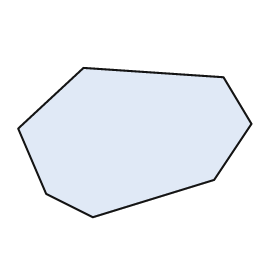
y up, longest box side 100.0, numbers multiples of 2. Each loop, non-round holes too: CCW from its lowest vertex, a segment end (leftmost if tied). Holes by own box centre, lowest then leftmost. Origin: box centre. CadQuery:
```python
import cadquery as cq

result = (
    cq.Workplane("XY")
    .moveTo(-18.0, -32.0)
    .lineTo(34.0, -16.0)
    .lineTo(50.0, 8.0)
    .lineTo(38.0, 28.0)
    .lineTo(-22.0, 32.0)
    .lineTo(-50.0, 6.0)
    .lineTo(-38.0, -22.0)
    .close()
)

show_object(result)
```